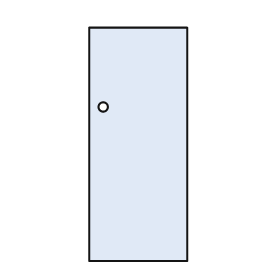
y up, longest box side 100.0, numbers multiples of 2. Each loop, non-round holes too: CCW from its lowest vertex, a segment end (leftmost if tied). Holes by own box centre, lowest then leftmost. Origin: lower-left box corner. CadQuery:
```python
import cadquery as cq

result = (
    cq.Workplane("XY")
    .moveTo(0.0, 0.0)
    .lineTo(42.0, 0.0)
    .lineTo(42.0, 100.0)
    .lineTo(0.0, 100.0)
    .close()
    .moveTo(6.0, 66.0)
    .circle(2.0)
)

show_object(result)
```